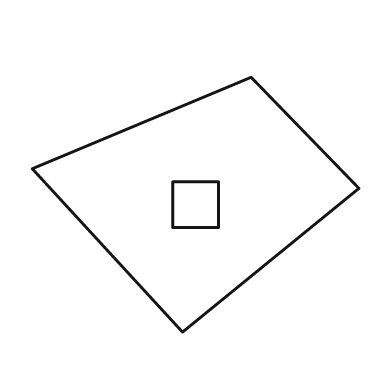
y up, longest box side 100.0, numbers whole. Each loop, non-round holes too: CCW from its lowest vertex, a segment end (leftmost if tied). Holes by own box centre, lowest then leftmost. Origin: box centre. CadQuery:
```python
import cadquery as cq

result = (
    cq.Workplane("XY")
    .moveTo(-4.0, -39.0)
    .lineTo(50.0, 5.0)
    .lineTo(17.0, 39.0)
    .lineTo(-50.0, 11.0)
    .close()
    .moveTo(-7.0, -7.0)
    .lineTo(7.0, -7.0)
    .lineTo(7.0, 7.0)
    .lineTo(-7.0, 7.0)
    .close()
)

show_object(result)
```